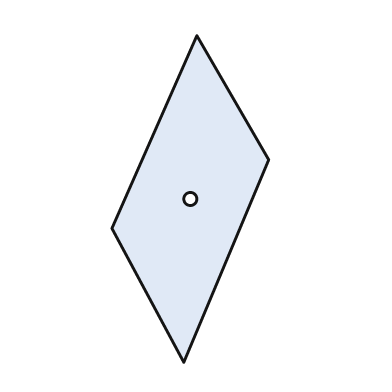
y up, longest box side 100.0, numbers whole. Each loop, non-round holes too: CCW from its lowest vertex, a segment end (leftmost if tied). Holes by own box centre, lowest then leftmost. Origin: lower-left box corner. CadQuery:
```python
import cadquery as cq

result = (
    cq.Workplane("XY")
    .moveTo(22.0, 0.0)
    .lineTo(48.0, 62.0)
    .lineTo(26.0, 100.0)
    .lineTo(0.0, 41.0)
    .close()
    .moveTo(24.0, 50.0)
    .circle(2.0)
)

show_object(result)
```